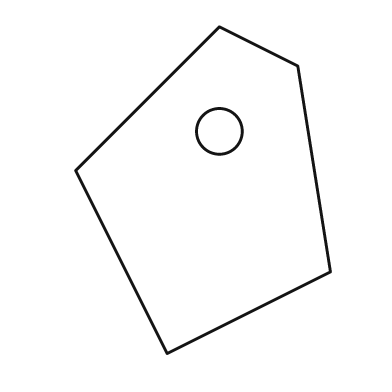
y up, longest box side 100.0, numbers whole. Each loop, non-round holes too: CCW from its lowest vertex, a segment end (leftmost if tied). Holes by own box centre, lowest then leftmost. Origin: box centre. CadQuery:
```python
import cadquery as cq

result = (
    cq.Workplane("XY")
    .moveTo(-11.0, -50.0)
    .lineTo(39.0, -25.0)
    .lineTo(29.0, 38.0)
    .lineTo(5.0, 50.0)
    .lineTo(-39.0, 6.0)
    .close()
    .moveTo(5.0, 18.0)
    .circle(7.0)
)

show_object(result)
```